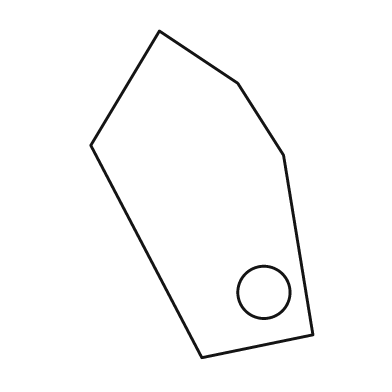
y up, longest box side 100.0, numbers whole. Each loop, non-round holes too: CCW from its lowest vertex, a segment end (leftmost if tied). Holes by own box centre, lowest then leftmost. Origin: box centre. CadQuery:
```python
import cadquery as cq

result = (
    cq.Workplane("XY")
    .moveTo(0.0, -50.0)
    .lineTo(34.0, -43.0)
    .lineTo(25.0, 12.0)
    .lineTo(11.0, 34.0)
    .lineTo(-13.0, 50.0)
    .lineTo(-34.0, 15.0)
    .close()
    .moveTo(19.0, -30.0)
    .circle(8.0)
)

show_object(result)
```